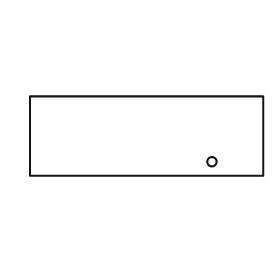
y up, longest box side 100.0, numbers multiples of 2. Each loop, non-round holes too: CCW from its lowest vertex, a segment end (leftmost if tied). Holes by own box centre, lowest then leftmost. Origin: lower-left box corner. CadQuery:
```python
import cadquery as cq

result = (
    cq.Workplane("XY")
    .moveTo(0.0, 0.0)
    .lineTo(100.0, 0.0)
    .lineTo(100.0, 34.0)
    .lineTo(0.0, 34.0)
    .close()
    .moveTo(78.0, 6.0)
    .circle(2.0)
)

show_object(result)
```